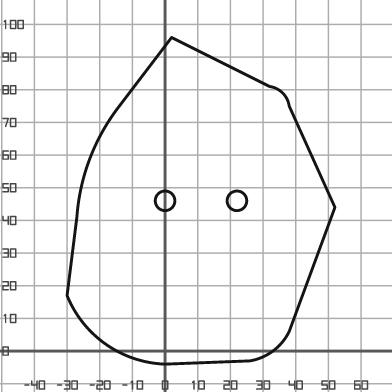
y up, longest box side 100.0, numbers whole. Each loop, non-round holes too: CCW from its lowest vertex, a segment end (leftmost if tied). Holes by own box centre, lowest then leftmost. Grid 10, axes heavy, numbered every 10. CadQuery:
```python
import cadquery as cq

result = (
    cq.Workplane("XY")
    .moveTo(0.0, -4.0)
    .lineTo(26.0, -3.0)
    .threePointArc((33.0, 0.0), (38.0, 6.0))
    .lineTo(52.0, 44.0)
    .lineTo(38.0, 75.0)
    .threePointArc((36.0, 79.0), (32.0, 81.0))
    .lineTo(2.0, 96.0)
    .lineTo(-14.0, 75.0)
    .threePointArc((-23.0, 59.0), (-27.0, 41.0))
    .lineTo(-30.0, 17.0)
    .threePointArc((-18.0, 2.0), (0.0, -4.0))
    .close()
    .moveTo(0.0, 46.0)
    .circle(3.0)
    .moveTo(22.0, 46.0)
    .circle(3.0)
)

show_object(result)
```